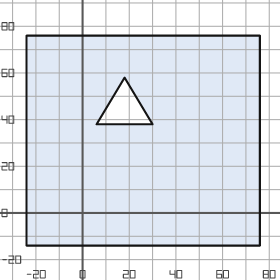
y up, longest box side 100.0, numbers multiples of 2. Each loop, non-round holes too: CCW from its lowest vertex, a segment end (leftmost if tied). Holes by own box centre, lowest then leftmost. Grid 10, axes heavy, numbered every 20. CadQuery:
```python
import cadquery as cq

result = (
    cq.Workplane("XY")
    .moveTo(-24.0, -14.0)
    .lineTo(76.0, -14.0)
    .lineTo(76.0, 76.0)
    .lineTo(-24.0, 76.0)
    .close()
    .moveTo(6.0, 38.0)
    .lineTo(30.0, 38.0)
    .lineTo(18.0, 58.0)
    .close()
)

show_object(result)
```